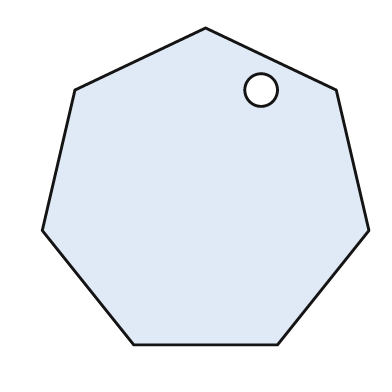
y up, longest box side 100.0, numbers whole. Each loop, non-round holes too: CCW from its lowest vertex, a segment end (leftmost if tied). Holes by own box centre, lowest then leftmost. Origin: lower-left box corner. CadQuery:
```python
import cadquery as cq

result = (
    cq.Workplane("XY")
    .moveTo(28.0, 0.0)
    .lineTo(72.0, 0.0)
    .lineTo(100.0, 35.0)
    .lineTo(90.0, 78.0)
    .lineTo(50.0, 97.0)
    .lineTo(10.0, 78.0)
    .lineTo(0.0, 35.0)
    .close()
    .moveTo(67.0, 78.0)
    .circle(5.0)
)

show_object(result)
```